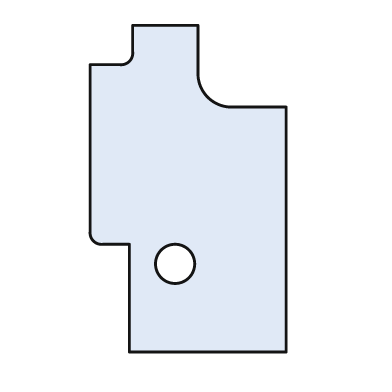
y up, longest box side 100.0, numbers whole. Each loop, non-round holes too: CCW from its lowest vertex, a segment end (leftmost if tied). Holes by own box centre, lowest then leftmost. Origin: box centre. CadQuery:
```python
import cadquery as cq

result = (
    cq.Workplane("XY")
    .moveTo(-18.0, -50.0)
    .lineTo(30.0, -50.0)
    .lineTo(30.0, 25.0)
    .lineTo(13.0, 25.0)
    .threePointArc((6.0, 28.0), (3.0, 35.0))
    .lineTo(3.0, 50.0)
    .lineTo(-17.0, 50.0)
    .lineTo(-17.0, 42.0)
    .threePointArc((-18.0, 39.0), (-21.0, 38.0))
    .lineTo(-30.0, 38.0)
    .lineTo(-30.0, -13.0)
    .threePointArc((-29.0, -16.0), (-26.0, -17.0))
    .lineTo(-18.0, -17.0)
    .close()
    .moveTo(-4.0, -23.0)
    .circle(6.0)
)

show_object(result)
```